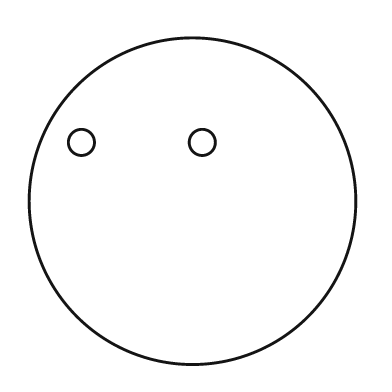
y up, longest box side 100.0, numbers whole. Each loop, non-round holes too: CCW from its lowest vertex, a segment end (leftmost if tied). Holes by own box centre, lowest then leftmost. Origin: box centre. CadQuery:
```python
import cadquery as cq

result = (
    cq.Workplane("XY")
    .moveTo(0.0, 0.0)
    .circle(50.0)
    .moveTo(-34.0, 18.0)
    .circle(4.0)
    .moveTo(3.0, 18.0)
    .circle(4.0)
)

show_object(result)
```